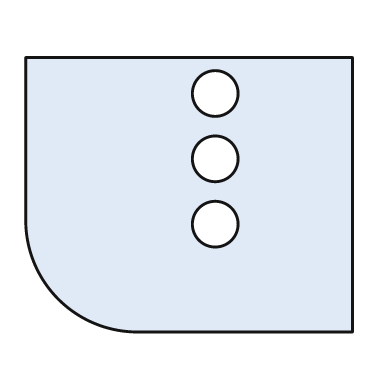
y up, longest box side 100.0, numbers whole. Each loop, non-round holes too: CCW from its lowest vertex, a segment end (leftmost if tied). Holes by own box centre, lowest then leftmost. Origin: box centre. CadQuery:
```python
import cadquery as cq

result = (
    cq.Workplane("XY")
    .moveTo(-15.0, -42.0)
    .lineTo(50.0, -42.0)
    .lineTo(50.0, 42.0)
    .lineTo(-50.0, 42.0)
    .lineTo(-50.0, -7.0)
    .threePointArc((-40.0, -32.0), (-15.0, -42.0))
    .close()
    .moveTo(8.0, -9.0)
    .circle(7.0)
    .moveTo(8.0, 11.0)
    .circle(7.0)
    .moveTo(8.0, 31.0)
    .circle(7.0)
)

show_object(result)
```